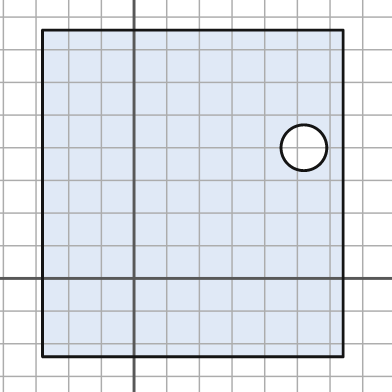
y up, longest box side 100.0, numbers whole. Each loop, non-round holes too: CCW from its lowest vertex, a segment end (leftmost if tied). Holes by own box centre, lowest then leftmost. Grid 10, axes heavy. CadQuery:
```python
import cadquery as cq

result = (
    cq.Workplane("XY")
    .moveTo(-28.0, -24.0)
    .lineTo(64.0, -24.0)
    .lineTo(64.0, 76.0)
    .lineTo(-28.0, 76.0)
    .close()
    .moveTo(52.0, 40.0)
    .circle(7.0)
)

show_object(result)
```